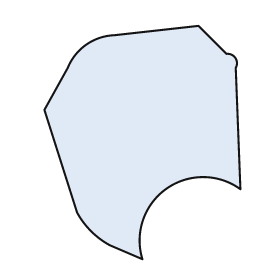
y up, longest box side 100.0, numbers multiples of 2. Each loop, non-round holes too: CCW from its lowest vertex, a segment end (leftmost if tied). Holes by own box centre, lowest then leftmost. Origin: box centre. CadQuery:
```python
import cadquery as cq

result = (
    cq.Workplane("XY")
    .moveTo(0.0, -50.0)
    .threePointArc((10.0, -20.0), (42.0, -20.0))
    .lineTo(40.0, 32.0)
    .threePointArc((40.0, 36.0), (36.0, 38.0))
    .lineTo(24.0, 50.0)
    .lineTo(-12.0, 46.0)
    .threePointArc((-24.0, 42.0), (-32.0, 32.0))
    .lineTo(-42.0, 14.0)
    .lineTo(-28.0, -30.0)
    .threePointArc((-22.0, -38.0), (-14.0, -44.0))
    .close()
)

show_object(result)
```